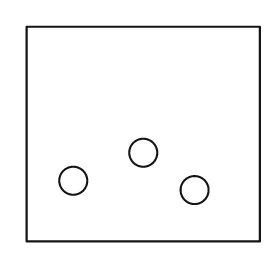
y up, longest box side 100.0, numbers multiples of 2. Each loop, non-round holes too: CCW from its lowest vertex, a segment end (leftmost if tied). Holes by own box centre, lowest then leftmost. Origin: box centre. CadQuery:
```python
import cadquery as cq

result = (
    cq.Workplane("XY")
    .moveTo(-50.0, -46.0)
    .lineTo(50.0, -46.0)
    .lineTo(50.0, 46.0)
    .lineTo(-50.0, 46.0)
    .close()
    .moveTo(22.0, -24.0)
    .circle(6.0)
    .moveTo(-30.0, -20.0)
    .circle(6.0)
    .moveTo(0.0, -8.0)
    .circle(6.0)
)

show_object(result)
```